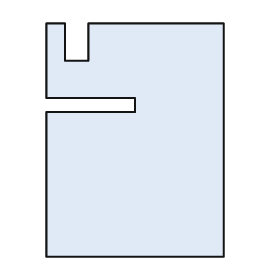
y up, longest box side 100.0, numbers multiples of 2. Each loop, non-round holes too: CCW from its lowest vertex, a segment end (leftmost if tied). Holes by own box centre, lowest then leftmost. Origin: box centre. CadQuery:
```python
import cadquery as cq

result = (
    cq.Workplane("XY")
    .moveTo(-38.0, -50.0)
    .lineTo(38.0, -50.0)
    .lineTo(38.0, 50.0)
    .lineTo(-20.0, 50.0)
    .lineTo(-20.0, 34.0)
    .lineTo(-30.0, 34.0)
    .lineTo(-30.0, 50.0)
    .lineTo(-38.0, 50.0)
    .lineTo(-38.0, 18.0)
    .lineTo(0.0, 18.0)
    .lineTo(0.0, 12.0)
    .lineTo(-38.0, 12.0)
    .close()
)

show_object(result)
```